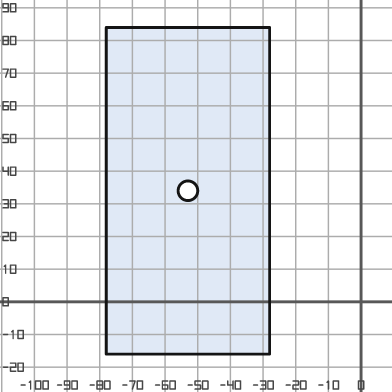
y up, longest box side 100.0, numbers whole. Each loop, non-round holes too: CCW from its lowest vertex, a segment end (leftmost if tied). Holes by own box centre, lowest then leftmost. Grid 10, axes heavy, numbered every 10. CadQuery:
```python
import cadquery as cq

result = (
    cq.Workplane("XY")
    .moveTo(-78.0, -16.0)
    .lineTo(-28.0, -16.0)
    .lineTo(-28.0, 84.0)
    .lineTo(-78.0, 84.0)
    .close()
    .moveTo(-53.0, 34.0)
    .circle(3.0)
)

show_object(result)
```